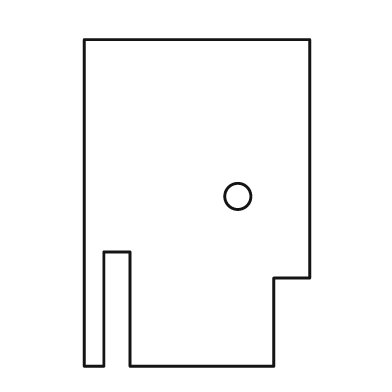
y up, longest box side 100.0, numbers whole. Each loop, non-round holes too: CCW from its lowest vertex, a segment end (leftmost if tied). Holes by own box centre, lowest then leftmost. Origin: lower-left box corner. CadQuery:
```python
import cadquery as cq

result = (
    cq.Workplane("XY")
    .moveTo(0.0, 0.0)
    .lineTo(6.0, 0.0)
    .lineTo(6.0, 35.0)
    .lineTo(14.0, 35.0)
    .lineTo(14.0, 0.0)
    .lineTo(58.0, 0.0)
    .lineTo(58.0, 27.0)
    .lineTo(69.0, 27.0)
    .lineTo(69.0, 100.0)
    .lineTo(0.0, 100.0)
    .close()
    .moveTo(47.0, 52.0)
    .circle(4.0)
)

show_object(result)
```